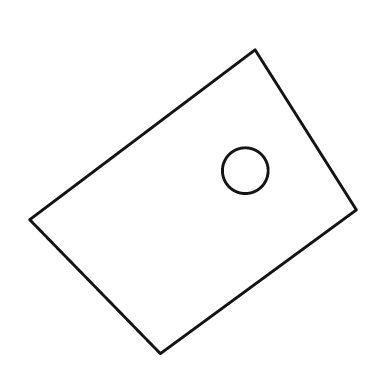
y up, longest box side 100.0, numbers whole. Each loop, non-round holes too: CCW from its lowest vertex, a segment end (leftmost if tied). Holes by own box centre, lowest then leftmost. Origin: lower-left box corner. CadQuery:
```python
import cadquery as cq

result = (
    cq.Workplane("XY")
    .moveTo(40.0, 0.0)
    .lineTo(100.0, 44.0)
    .lineTo(69.0, 93.0)
    .lineTo(0.0, 41.0)
    .close()
    .moveTo(66.0, 56.0)
    .circle(7.0)
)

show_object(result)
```